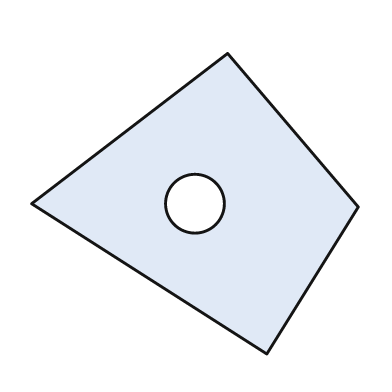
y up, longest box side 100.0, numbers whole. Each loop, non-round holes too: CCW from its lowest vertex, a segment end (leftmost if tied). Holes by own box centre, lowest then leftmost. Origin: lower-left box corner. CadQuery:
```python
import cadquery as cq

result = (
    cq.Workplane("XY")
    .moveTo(72.0, 0.0)
    .lineTo(100.0, 45.0)
    .lineTo(60.0, 92.0)
    .lineTo(0.0, 46.0)
    .close()
    .moveTo(50.0, 46.0)
    .circle(9.0)
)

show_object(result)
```